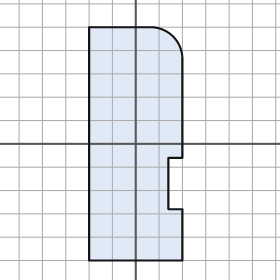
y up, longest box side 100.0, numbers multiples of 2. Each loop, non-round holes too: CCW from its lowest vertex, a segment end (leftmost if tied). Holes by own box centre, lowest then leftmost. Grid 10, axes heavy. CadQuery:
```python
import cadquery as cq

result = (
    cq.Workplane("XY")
    .moveTo(-20.0, -50.0)
    .lineTo(20.0, -50.0)
    .lineTo(20.0, -28.0)
    .lineTo(14.0, -28.0)
    .lineTo(14.0, -6.0)
    .lineTo(20.0, -6.0)
    .lineTo(20.0, 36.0)
    .threePointArc((16.0, 46.0), (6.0, 50.0))
    .lineTo(-20.0, 50.0)
    .close()
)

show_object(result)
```